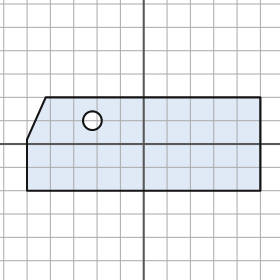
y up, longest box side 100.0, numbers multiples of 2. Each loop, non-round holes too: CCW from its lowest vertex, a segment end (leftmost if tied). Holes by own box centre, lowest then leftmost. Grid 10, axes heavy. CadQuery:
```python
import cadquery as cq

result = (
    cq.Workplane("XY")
    .moveTo(-50.0, -20.0)
    .lineTo(50.0, -20.0)
    .lineTo(50.0, 20.0)
    .lineTo(-42.0, 20.0)
    .lineTo(-50.0, 2.0)
    .close()
    .moveTo(-22.0, 10.0)
    .circle(4.0)
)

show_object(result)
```